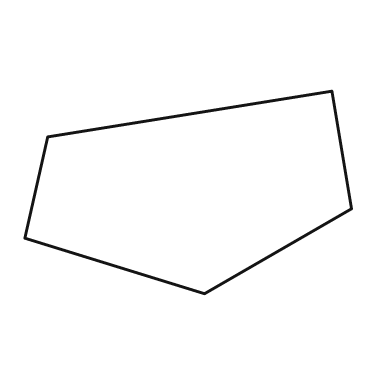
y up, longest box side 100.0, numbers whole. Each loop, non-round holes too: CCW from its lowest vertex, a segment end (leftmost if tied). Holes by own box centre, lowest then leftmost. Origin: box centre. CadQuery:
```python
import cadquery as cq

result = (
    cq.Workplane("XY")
    .moveTo(5.0, -31.0)
    .lineTo(50.0, -5.0)
    .lineTo(44.0, 31.0)
    .lineTo(-43.0, 17.0)
    .lineTo(-50.0, -14.0)
    .close()
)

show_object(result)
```